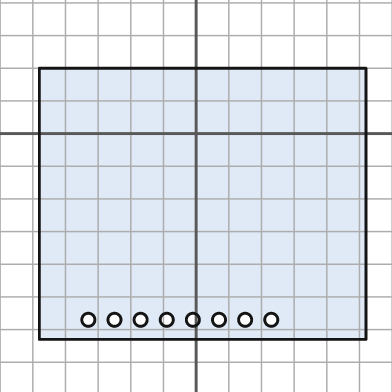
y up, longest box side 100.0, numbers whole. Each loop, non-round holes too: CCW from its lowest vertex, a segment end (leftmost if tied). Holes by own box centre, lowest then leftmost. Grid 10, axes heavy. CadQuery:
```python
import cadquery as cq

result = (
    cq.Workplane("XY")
    .moveTo(-48.0, -63.0)
    .lineTo(52.0, -63.0)
    .lineTo(52.0, 20.0)
    .lineTo(-48.0, 20.0)
    .close()
    .moveTo(-33.0, -57.0)
    .circle(2.0)
    .moveTo(-25.0, -57.0)
    .circle(2.0)
    .moveTo(-17.0, -57.0)
    .circle(2.0)
    .moveTo(-9.0, -57.0)
    .circle(2.0)
    .moveTo(-1.0, -57.0)
    .circle(2.0)
    .moveTo(7.0, -57.0)
    .circle(2.0)
    .moveTo(15.0, -57.0)
    .circle(2.0)
    .moveTo(23.0, -57.0)
    .circle(2.0)
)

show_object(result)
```